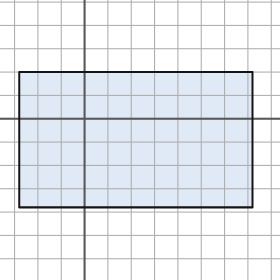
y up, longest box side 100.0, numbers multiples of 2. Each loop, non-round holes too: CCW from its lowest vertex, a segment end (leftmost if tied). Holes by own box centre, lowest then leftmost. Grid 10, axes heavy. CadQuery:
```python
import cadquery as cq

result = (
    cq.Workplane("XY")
    .moveTo(-28.0, -38.0)
    .lineTo(72.0, -38.0)
    .lineTo(72.0, 20.0)
    .lineTo(-28.0, 20.0)
    .close()
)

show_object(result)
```